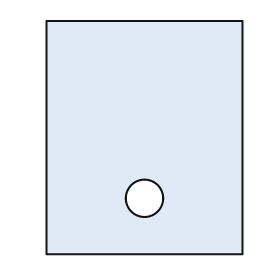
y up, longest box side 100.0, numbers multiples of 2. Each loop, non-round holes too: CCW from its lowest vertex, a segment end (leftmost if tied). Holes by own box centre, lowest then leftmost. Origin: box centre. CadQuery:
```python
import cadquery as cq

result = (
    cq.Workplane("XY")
    .moveTo(-42.0, -50.0)
    .lineTo(42.0, -50.0)
    .lineTo(42.0, 50.0)
    .lineTo(-42.0, 50.0)
    .close()
    .moveTo(0.0, -26.0)
    .circle(8.0)
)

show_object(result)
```